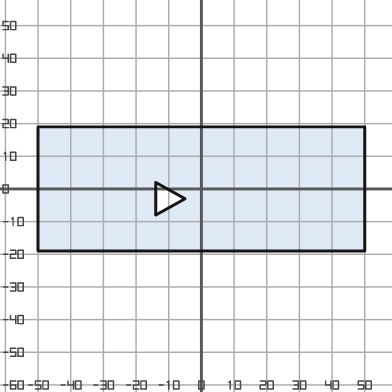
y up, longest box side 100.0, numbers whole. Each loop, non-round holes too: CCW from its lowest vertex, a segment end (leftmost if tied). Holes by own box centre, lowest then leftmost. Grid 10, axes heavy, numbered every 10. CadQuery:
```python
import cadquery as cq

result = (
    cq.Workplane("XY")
    .moveTo(-50.0, -19.0)
    .lineTo(50.0, -19.0)
    .lineTo(50.0, 19.0)
    .lineTo(-50.0, 19.0)
    .close()
    .moveTo(-14.0, -8.0)
    .lineTo(-5.0, -3.0)
    .lineTo(-14.0, 2.0)
    .close()
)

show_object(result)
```